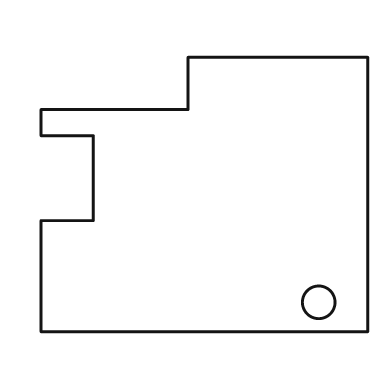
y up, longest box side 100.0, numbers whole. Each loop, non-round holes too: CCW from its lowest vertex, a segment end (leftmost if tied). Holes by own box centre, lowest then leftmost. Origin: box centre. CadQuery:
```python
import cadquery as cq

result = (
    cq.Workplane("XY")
    .moveTo(-50.0, -42.0)
    .lineTo(50.0, -42.0)
    .lineTo(50.0, 42.0)
    .lineTo(-5.0, 42.0)
    .lineTo(-5.0, 26.0)
    .lineTo(-50.0, 26.0)
    .lineTo(-50.0, 18.0)
    .lineTo(-34.0, 18.0)
    .lineTo(-34.0, -8.0)
    .lineTo(-50.0, -8.0)
    .close()
    .moveTo(35.0, -33.0)
    .circle(5.0)
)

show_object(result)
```